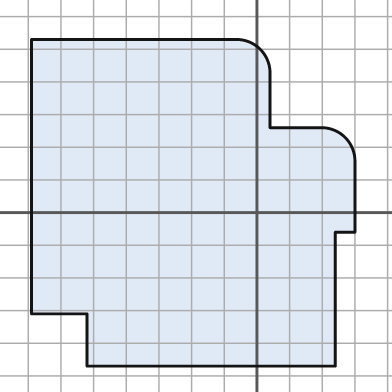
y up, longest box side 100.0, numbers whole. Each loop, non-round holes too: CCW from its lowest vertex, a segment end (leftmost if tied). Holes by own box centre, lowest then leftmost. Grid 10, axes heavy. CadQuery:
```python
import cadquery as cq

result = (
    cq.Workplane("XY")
    .moveTo(-52.0, -47.0)
    .lineTo(24.0, -47.0)
    .lineTo(24.0, -6.0)
    .lineTo(30.0, -6.0)
    .lineTo(30.0, 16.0)
    .threePointArc((27.0, 23.0), (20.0, 26.0))
    .lineTo(4.0, 26.0)
    .lineTo(4.0, 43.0)
    .threePointArc((1.0, 50.0), (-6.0, 53.0))
    .lineTo(-69.0, 53.0)
    .lineTo(-69.0, -31.0)
    .lineTo(-52.0, -31.0)
    .close()
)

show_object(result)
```